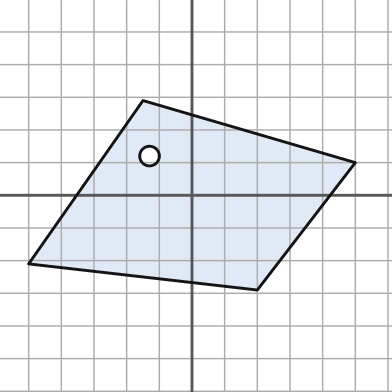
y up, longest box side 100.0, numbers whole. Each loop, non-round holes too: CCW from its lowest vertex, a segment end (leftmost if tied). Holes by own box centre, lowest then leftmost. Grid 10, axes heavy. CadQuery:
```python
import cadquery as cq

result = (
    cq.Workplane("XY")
    .moveTo(20.0, -29.0)
    .lineTo(50.0, 10.0)
    .lineTo(-15.0, 29.0)
    .lineTo(-50.0, -21.0)
    .close()
    .moveTo(-13.0, 12.0)
    .circle(3.0)
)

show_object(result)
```